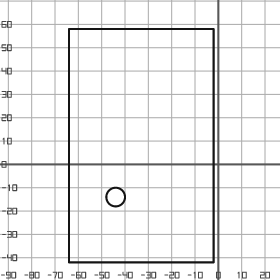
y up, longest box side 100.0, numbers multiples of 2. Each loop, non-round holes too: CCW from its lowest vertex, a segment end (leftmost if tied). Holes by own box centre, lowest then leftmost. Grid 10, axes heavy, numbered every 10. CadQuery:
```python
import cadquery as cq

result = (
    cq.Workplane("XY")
    .moveTo(-64.0, -42.0)
    .lineTo(-2.0, -42.0)
    .lineTo(-2.0, 58.0)
    .lineTo(-64.0, 58.0)
    .close()
    .moveTo(-44.0, -14.0)
    .circle(4.0)
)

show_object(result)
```